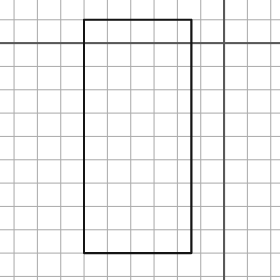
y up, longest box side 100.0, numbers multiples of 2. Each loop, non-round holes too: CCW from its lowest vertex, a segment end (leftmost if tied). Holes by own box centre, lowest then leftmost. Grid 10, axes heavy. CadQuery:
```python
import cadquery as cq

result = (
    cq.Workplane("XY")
    .moveTo(-60.0, -90.0)
    .lineTo(-14.0, -90.0)
    .lineTo(-14.0, 10.0)
    .lineTo(-60.0, 10.0)
    .close()
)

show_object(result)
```